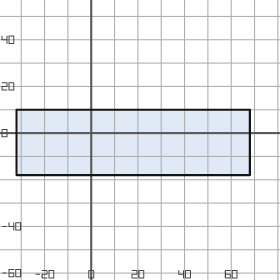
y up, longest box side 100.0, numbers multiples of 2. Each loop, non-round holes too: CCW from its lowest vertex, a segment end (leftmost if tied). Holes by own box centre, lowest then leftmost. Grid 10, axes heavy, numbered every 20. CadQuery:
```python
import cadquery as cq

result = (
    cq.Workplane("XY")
    .moveTo(-32.0, -18.0)
    .lineTo(68.0, -18.0)
    .lineTo(68.0, 10.0)
    .lineTo(-32.0, 10.0)
    .close()
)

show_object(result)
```